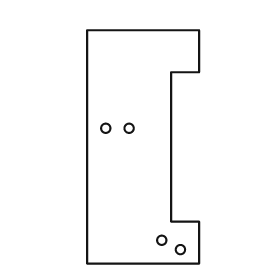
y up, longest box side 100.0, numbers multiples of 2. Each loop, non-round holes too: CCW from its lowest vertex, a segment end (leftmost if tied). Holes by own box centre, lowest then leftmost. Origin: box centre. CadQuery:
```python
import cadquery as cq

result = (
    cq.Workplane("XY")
    .moveTo(-24.0, -50.0)
    .lineTo(24.0, -50.0)
    .lineTo(24.0, -32.0)
    .lineTo(12.0, -32.0)
    .lineTo(12.0, 32.0)
    .lineTo(24.0, 32.0)
    .lineTo(24.0, 50.0)
    .lineTo(-24.0, 50.0)
    .close()
    .moveTo(16.0, -44.0)
    .circle(2.0)
    .moveTo(8.0, -40.0)
    .circle(2.0)
    .moveTo(-16.0, 8.0)
    .circle(2.0)
    .moveTo(-6.0, 8.0)
    .circle(2.0)
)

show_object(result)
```